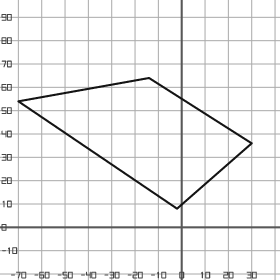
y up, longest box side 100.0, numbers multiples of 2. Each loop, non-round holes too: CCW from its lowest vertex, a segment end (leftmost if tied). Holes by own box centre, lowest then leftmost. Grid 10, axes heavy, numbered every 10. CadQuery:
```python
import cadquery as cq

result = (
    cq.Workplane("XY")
    .moveTo(-2.0, 8.0)
    .lineTo(30.0, 36.0)
    .lineTo(-14.0, 64.0)
    .lineTo(-70.0, 54.0)
    .close()
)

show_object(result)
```